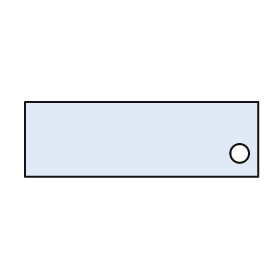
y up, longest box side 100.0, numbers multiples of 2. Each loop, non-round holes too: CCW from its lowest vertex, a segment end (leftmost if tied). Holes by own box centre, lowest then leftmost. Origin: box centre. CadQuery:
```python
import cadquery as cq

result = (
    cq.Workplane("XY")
    .moveTo(-50.0, -16.0)
    .lineTo(50.0, -16.0)
    .lineTo(50.0, 16.0)
    .lineTo(-50.0, 16.0)
    .close()
    .moveTo(42.0, -6.0)
    .circle(4.0)
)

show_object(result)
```